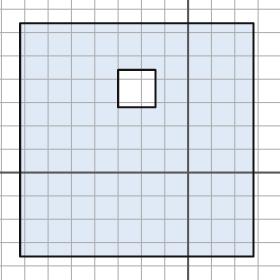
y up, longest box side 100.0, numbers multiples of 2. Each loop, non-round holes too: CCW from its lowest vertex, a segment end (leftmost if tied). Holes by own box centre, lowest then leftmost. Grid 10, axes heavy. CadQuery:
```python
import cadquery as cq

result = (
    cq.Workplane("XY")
    .moveTo(-72.0, -36.0)
    .lineTo(28.0, -36.0)
    .lineTo(28.0, 64.0)
    .lineTo(-72.0, 64.0)
    .close()
    .moveTo(-30.0, 28.0)
    .lineTo(-14.0, 28.0)
    .lineTo(-14.0, 44.0)
    .lineTo(-30.0, 44.0)
    .close()
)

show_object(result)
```